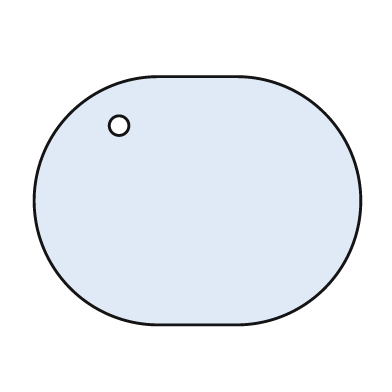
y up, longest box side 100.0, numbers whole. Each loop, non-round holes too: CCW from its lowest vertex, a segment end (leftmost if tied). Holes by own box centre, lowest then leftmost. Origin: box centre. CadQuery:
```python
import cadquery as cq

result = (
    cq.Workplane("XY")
    .moveTo(-12.0, -38.0)
    .lineTo(12.0, -38.0)
    .threePointArc((50.0, 0.0), (12.0, 38.0))
    .lineTo(-12.0, 38.0)
    .threePointArc((-50.0, 0.0), (-12.0, -38.0))
    .close()
    .moveTo(-24.0, 23.0)
    .circle(3.0)
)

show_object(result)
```